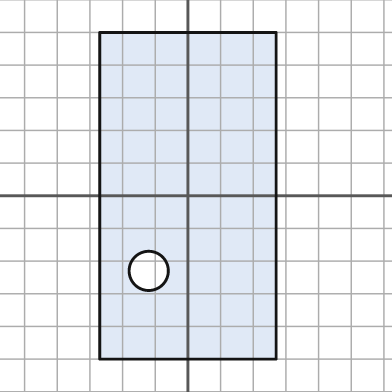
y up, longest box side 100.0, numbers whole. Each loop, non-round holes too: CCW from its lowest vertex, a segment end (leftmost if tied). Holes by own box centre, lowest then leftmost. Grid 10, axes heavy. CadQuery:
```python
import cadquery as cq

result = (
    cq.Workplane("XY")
    .moveTo(-27.0, -50.0)
    .lineTo(27.0, -50.0)
    .lineTo(27.0, 50.0)
    .lineTo(-27.0, 50.0)
    .close()
    .moveTo(-12.0, -23.0)
    .circle(6.0)
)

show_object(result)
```